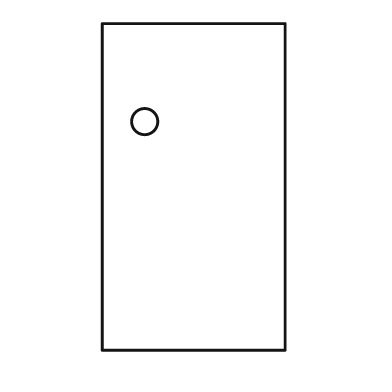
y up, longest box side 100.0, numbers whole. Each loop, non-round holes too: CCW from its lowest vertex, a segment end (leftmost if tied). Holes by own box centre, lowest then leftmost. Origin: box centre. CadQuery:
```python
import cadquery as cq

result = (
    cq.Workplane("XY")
    .moveTo(-28.0, -50.0)
    .lineTo(28.0, -50.0)
    .lineTo(28.0, 50.0)
    .lineTo(-28.0, 50.0)
    .close()
    .moveTo(-15.0, 20.0)
    .circle(4.0)
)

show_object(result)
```